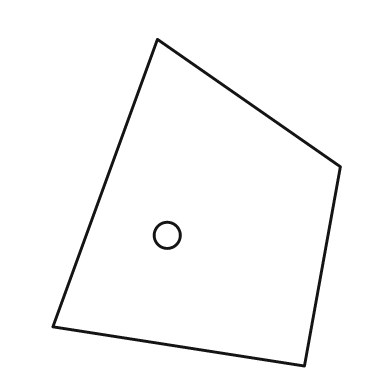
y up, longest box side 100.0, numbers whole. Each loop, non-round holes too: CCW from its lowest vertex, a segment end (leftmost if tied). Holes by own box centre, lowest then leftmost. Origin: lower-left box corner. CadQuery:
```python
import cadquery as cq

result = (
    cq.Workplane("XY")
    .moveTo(77.0, 0.0)
    .lineTo(88.0, 61.0)
    .lineTo(32.0, 100.0)
    .lineTo(0.0, 12.0)
    .close()
    .moveTo(35.0, 40.0)
    .circle(4.0)
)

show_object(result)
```